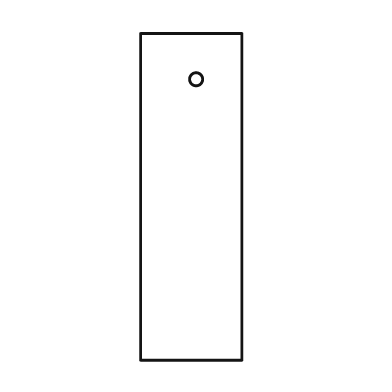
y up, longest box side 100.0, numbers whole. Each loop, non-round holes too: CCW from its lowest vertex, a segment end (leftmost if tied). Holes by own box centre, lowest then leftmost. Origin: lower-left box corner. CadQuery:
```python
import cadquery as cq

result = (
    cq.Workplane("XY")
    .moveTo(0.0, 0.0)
    .lineTo(31.0, 0.0)
    .lineTo(31.0, 100.0)
    .lineTo(0.0, 100.0)
    .close()
    .moveTo(17.0, 86.0)
    .circle(2.0)
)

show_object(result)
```